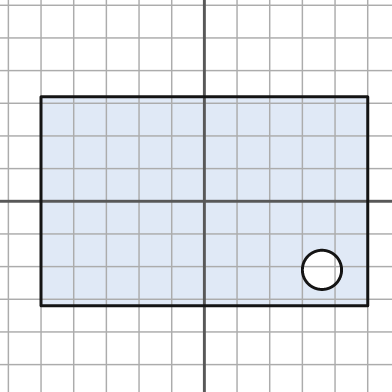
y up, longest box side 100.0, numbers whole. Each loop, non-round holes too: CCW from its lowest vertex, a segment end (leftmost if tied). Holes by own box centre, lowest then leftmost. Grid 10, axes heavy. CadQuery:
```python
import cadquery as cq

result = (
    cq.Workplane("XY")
    .moveTo(-50.0, -32.0)
    .lineTo(50.0, -32.0)
    .lineTo(50.0, 32.0)
    .lineTo(-50.0, 32.0)
    .close()
    .moveTo(36.0, -21.0)
    .circle(6.0)
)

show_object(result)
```